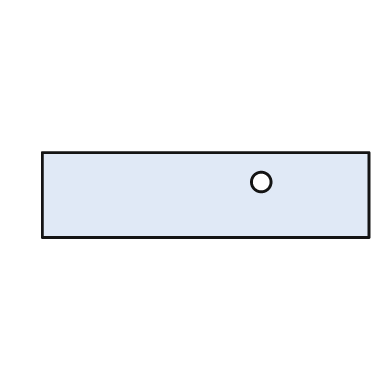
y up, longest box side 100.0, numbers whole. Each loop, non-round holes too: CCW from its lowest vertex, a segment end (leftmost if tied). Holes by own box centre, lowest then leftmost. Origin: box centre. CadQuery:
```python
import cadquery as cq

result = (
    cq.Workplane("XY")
    .moveTo(-50.0, -13.0)
    .lineTo(50.0, -13.0)
    .lineTo(50.0, 13.0)
    .lineTo(-50.0, 13.0)
    .close()
    .moveTo(17.0, 4.0)
    .circle(3.0)
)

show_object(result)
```